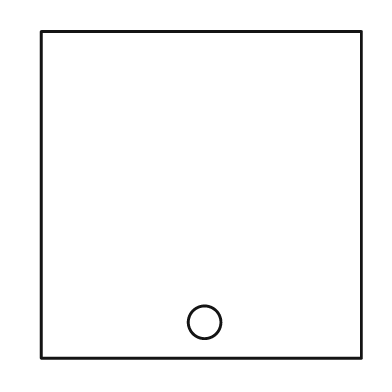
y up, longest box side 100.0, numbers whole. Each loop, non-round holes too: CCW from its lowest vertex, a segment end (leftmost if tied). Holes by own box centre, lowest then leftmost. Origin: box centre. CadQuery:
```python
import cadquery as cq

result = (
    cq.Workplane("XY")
    .moveTo(-49.0, -50.0)
    .lineTo(49.0, -50.0)
    .lineTo(49.0, 50.0)
    .lineTo(-49.0, 50.0)
    .close()
    .moveTo(1.0, -39.0)
    .circle(5.0)
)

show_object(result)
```